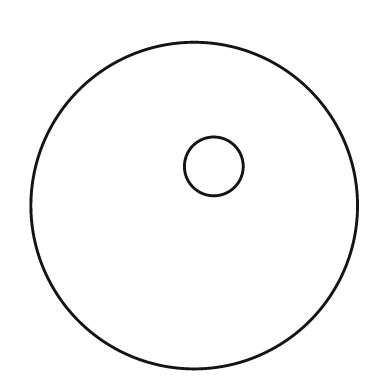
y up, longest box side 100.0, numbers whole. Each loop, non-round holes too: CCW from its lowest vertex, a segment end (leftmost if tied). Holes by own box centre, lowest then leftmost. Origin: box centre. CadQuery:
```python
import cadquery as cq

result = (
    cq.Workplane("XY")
    .moveTo(0.0, 0.0)
    .circle(50.0)
    .moveTo(6.0, 12.0)
    .circle(9.0)
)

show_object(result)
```